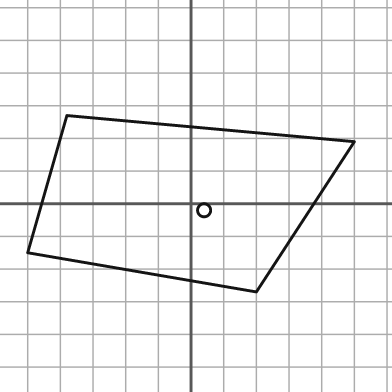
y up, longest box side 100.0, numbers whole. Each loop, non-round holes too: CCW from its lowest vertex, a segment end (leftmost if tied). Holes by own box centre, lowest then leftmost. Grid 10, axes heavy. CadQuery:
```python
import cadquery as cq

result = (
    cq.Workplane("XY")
    .moveTo(20.0, -27.0)
    .lineTo(50.0, 19.0)
    .lineTo(-38.0, 27.0)
    .lineTo(-50.0, -15.0)
    .close()
    .moveTo(4.0, -2.0)
    .circle(2.0)
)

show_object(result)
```